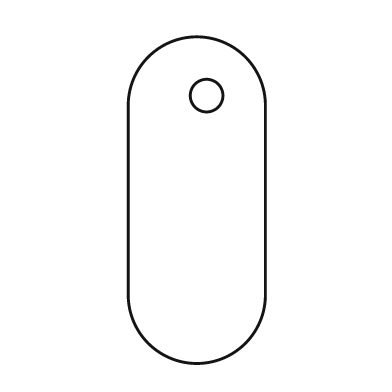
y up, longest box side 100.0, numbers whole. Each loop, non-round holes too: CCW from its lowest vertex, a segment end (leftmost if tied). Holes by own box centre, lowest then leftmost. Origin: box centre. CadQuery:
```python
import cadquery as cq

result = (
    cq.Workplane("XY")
    .moveTo(-21.0, -29.0)
    .threePointArc((0.0, -50.0), (21.0, -29.0))
    .lineTo(21.0, 29.0)
    .threePointArc((0.0, 50.0), (-21.0, 29.0))
    .close()
    .moveTo(3.0, 32.0)
    .circle(5.0)
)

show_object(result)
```